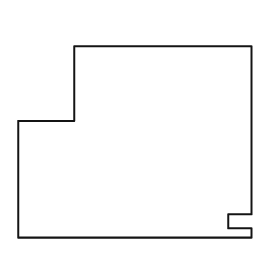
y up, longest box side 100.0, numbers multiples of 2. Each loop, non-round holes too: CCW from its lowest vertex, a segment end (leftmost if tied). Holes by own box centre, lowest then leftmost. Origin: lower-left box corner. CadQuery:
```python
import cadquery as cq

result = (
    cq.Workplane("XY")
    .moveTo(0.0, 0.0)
    .lineTo(100.0, 0.0)
    .lineTo(100.0, 4.0)
    .lineTo(90.0, 4.0)
    .lineTo(90.0, 10.0)
    .lineTo(100.0, 10.0)
    .lineTo(100.0, 82.0)
    .lineTo(24.0, 82.0)
    .lineTo(24.0, 50.0)
    .lineTo(0.0, 50.0)
    .close()
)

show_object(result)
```